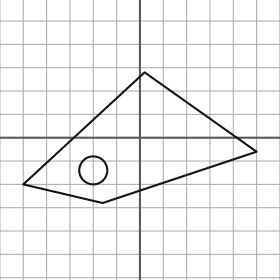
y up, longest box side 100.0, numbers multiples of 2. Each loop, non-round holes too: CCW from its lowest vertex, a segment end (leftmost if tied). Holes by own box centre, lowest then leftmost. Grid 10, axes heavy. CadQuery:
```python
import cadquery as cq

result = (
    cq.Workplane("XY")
    .moveTo(-16.0, -28.0)
    .lineTo(50.0, -6.0)
    .lineTo(2.0, 28.0)
    .lineTo(-50.0, -20.0)
    .close()
    .moveTo(-20.0, -14.0)
    .circle(6.0)
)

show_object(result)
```